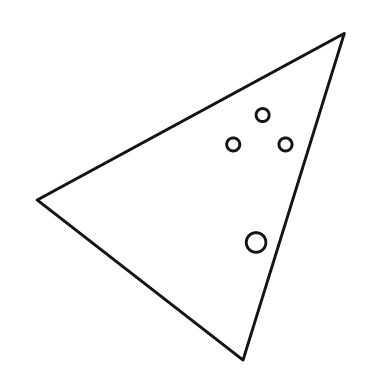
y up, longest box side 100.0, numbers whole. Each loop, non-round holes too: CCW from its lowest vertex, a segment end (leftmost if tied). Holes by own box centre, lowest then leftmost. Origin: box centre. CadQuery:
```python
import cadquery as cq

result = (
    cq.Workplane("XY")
    .moveTo(16.0, -50.0)
    .lineTo(47.0, 50.0)
    .lineTo(-47.0, -1.0)
    .close()
    .moveTo(20.0, -14.0)
    .circle(3.0)
    .moveTo(13.0, 16.0)
    .circle(2.0)
    .moveTo(29.0, 16.0)
    .circle(2.0)
    .moveTo(22.0, 25.0)
    .circle(2.0)
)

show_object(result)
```